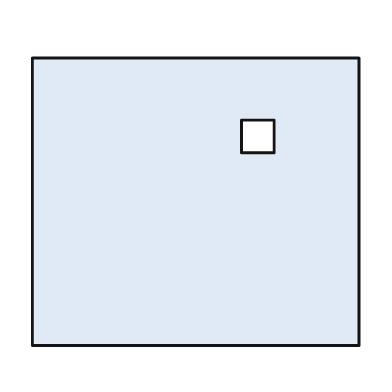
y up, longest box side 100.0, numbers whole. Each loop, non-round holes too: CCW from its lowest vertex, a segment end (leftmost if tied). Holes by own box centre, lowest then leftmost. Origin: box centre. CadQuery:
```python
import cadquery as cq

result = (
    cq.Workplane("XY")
    .moveTo(-50.0, -44.0)
    .lineTo(50.0, -44.0)
    .lineTo(50.0, 44.0)
    .lineTo(-50.0, 44.0)
    .close()
    .moveTo(14.0, 15.0)
    .lineTo(24.0, 15.0)
    .lineTo(24.0, 25.0)
    .lineTo(14.0, 25.0)
    .close()
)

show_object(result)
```